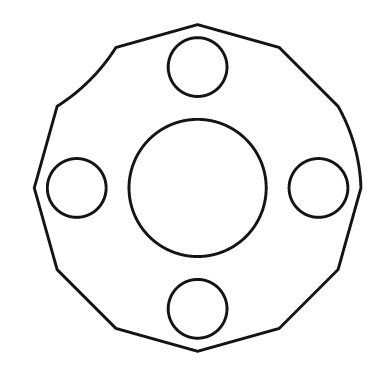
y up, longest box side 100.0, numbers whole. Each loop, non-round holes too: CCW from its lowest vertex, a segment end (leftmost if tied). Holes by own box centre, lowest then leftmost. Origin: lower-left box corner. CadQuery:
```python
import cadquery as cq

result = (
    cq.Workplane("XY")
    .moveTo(50.0, 0.0)
    .lineTo(75.0, 7.0)
    .lineTo(93.0, 25.0)
    .lineTo(100.0, 50.0)
    .threePointArc((98.0, 63.0), (93.0, 75.0))
    .lineTo(75.0, 93.0)
    .lineTo(50.0, 100.0)
    .lineTo(25.0, 93.0)
    .threePointArc((17.0, 83.0), (7.0, 75.0))
    .lineTo(0.0, 50.0)
    .lineTo(7.0, 25.0)
    .lineTo(25.0, 7.0)
    .close()
    .moveTo(50.0, 13.0)
    .circle(9.0)
    .moveTo(13.0, 50.0)
    .circle(9.0)
    .moveTo(50.0, 50.0)
    .circle(21.0)
    .moveTo(87.0, 50.0)
    .circle(9.0)
    .moveTo(50.0, 87.0)
    .circle(9.0)
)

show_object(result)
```